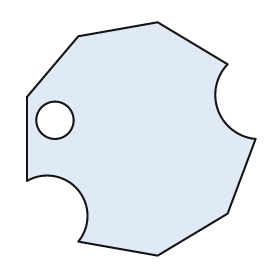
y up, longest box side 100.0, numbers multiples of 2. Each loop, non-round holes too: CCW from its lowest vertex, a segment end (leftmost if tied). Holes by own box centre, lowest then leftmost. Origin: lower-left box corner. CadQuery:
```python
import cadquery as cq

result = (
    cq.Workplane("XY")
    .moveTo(56.0, 0.0)
    .lineTo(86.0, 18.0)
    .lineTo(98.0, 50.0)
    .threePointArc((82.0, 62.0), (86.0, 82.0))
    .lineTo(56.0, 100.0)
    .lineTo(22.0, 94.0)
    .lineTo(0.0, 68.0)
    .lineTo(0.0, 32.0)
    .threePointArc((22.0, 28.0), (22.0, 6.0))
    .close()
    .moveTo(12.0, 58.0)
    .circle(8.0)
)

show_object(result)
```